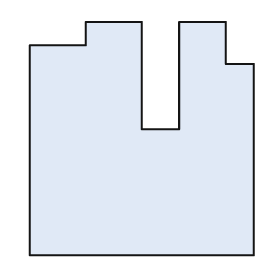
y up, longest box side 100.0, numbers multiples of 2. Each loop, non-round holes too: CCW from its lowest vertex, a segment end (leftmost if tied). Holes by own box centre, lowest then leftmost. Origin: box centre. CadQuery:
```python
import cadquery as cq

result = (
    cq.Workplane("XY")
    .moveTo(-48.0, -50.0)
    .lineTo(48.0, -50.0)
    .lineTo(48.0, 32.0)
    .lineTo(36.0, 32.0)
    .lineTo(36.0, 50.0)
    .lineTo(16.0, 50.0)
    .lineTo(16.0, 4.0)
    .lineTo(0.0, 4.0)
    .lineTo(0.0, 50.0)
    .lineTo(-24.0, 50.0)
    .lineTo(-24.0, 40.0)
    .lineTo(-48.0, 40.0)
    .close()
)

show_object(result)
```